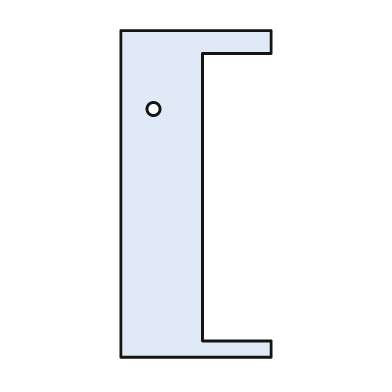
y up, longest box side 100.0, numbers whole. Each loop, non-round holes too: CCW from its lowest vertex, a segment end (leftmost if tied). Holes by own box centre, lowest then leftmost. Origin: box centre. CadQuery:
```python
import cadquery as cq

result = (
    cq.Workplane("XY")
    .moveTo(-23.0, -50.0)
    .lineTo(23.0, -50.0)
    .lineTo(23.0, -45.0)
    .lineTo(2.0, -45.0)
    .lineTo(2.0, 43.0)
    .lineTo(23.0, 43.0)
    .lineTo(23.0, 50.0)
    .lineTo(-23.0, 50.0)
    .close()
    .moveTo(-13.0, 26.0)
    .circle(2.0)
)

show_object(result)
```